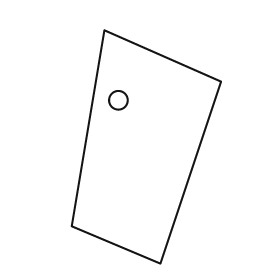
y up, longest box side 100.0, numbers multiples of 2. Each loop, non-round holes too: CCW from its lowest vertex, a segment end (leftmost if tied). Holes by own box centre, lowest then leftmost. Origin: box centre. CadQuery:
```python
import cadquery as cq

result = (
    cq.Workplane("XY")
    .moveTo(6.0, -50.0)
    .lineTo(32.0, 28.0)
    .lineTo(-18.0, 50.0)
    .lineTo(-32.0, -34.0)
    .close()
    .moveTo(-12.0, 20.0)
    .circle(4.0)
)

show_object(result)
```